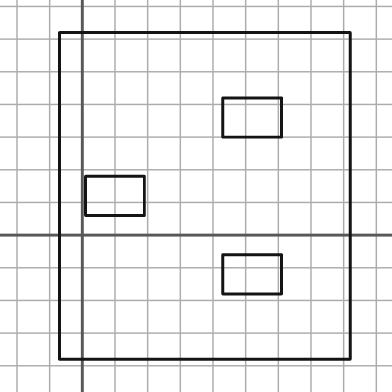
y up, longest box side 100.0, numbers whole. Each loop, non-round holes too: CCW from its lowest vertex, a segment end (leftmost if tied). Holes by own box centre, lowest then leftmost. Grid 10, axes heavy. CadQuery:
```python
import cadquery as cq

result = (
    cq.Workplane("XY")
    .moveTo(-7.0, -38.0)
    .lineTo(82.0, -38.0)
    .lineTo(82.0, 62.0)
    .lineTo(-7.0, 62.0)
    .close()
    .moveTo(43.0, -18.0)
    .lineTo(61.0, -18.0)
    .lineTo(61.0, -6.0)
    .lineTo(43.0, -6.0)
    .close()
    .moveTo(1.0, 6.0)
    .lineTo(19.0, 6.0)
    .lineTo(19.0, 18.0)
    .lineTo(1.0, 18.0)
    .close()
    .moveTo(43.0, 30.0)
    .lineTo(61.0, 30.0)
    .lineTo(61.0, 42.0)
    .lineTo(43.0, 42.0)
    .close()
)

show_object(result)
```